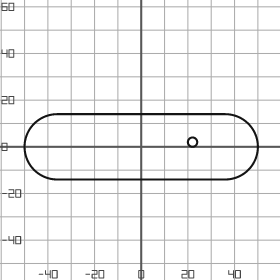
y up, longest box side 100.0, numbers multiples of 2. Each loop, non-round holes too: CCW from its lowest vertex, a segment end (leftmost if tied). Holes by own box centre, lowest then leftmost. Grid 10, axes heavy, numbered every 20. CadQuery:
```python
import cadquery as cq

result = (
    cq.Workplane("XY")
    .moveTo(-36.0, -14.0)
    .lineTo(36.0, -14.0)
    .threePointArc((50.0, 0.0), (36.0, 14.0))
    .lineTo(-36.0, 14.0)
    .threePointArc((-50.0, 0.0), (-36.0, -14.0))
    .close()
    .moveTo(22.0, 2.0)
    .circle(2.0)
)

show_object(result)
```